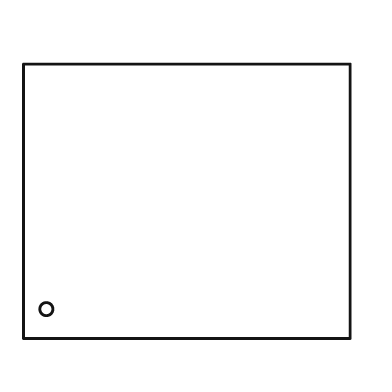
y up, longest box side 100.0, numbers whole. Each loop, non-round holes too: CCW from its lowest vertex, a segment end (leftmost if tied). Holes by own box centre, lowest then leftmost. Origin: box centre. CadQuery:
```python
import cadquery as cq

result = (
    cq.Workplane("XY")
    .moveTo(-50.0, -42.0)
    .lineTo(50.0, -42.0)
    .lineTo(50.0, 42.0)
    .lineTo(-50.0, 42.0)
    .close()
    .moveTo(-43.0, -33.0)
    .circle(2.0)
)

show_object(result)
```